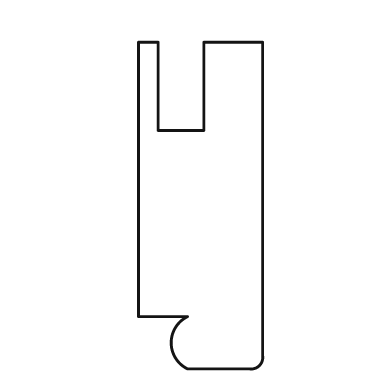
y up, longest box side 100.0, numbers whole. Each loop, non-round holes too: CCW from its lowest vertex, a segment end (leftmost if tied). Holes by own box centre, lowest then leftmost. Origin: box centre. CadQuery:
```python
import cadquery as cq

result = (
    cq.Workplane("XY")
    .moveTo(-4.0, -50.0)
    .lineTo(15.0, -50.0)
    .threePointArc((18.0, -49.0), (19.0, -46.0))
    .lineTo(19.0, 50.0)
    .lineTo(1.0, 50.0)
    .lineTo(1.0, 23.0)
    .lineTo(-13.0, 23.0)
    .lineTo(-13.0, 50.0)
    .lineTo(-19.0, 50.0)
    .lineTo(-19.0, -34.0)
    .lineTo(-4.0, -34.0)
    .threePointArc((-9.0, -42.0), (-4.0, -50.0))
    .close()
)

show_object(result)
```